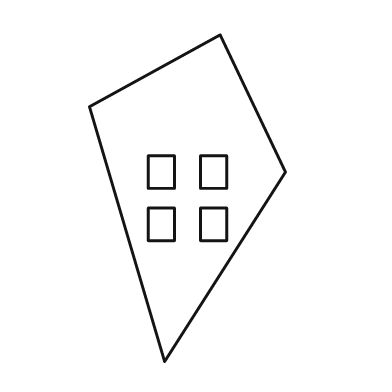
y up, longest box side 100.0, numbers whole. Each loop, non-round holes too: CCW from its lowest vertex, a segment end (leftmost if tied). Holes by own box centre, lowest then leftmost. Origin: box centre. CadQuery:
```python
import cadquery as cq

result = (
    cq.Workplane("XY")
    .moveTo(-7.0, -50.0)
    .lineTo(30.0, 8.0)
    .lineTo(10.0, 50.0)
    .lineTo(-30.0, 28.0)
    .close()
    .moveTo(-12.0, -13.0)
    .lineTo(-4.0, -13.0)
    .lineTo(-4.0, -3.0)
    .lineTo(-12.0, -3.0)
    .close()
    .moveTo(4.0, -13.0)
    .lineTo(12.0, -13.0)
    .lineTo(12.0, -3.0)
    .lineTo(4.0, -3.0)
    .close()
    .moveTo(-12.0, 3.0)
    .lineTo(-4.0, 3.0)
    .lineTo(-4.0, 13.0)
    .lineTo(-12.0, 13.0)
    .close()
    .moveTo(4.0, 3.0)
    .lineTo(12.0, 3.0)
    .lineTo(12.0, 13.0)
    .lineTo(4.0, 13.0)
    .close()
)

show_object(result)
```